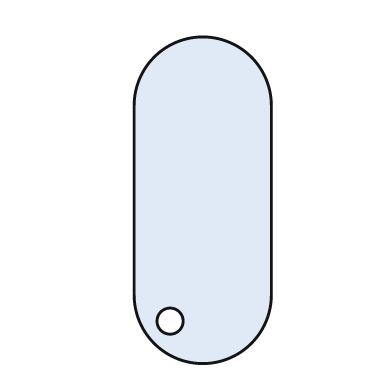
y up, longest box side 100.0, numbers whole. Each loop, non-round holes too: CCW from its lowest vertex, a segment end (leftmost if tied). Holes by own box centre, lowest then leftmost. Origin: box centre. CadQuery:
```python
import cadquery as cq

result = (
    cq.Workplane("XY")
    .moveTo(-21.0, -29.0)
    .threePointArc((0.0, -50.0), (21.0, -29.0))
    .lineTo(21.0, 29.0)
    .threePointArc((0.0, 50.0), (-21.0, 29.0))
    .close()
    .moveTo(-10.0, -37.0)
    .circle(4.0)
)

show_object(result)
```